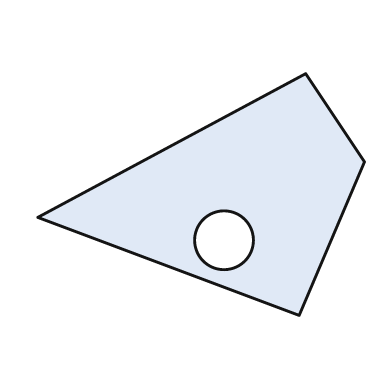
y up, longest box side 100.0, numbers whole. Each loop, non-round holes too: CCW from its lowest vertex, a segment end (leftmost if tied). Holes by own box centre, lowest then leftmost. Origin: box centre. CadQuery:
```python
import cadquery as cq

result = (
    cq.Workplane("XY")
    .moveTo(30.0, -37.0)
    .lineTo(50.0, 10.0)
    .lineTo(32.0, 37.0)
    .lineTo(-50.0, -7.0)
    .close()
    .moveTo(7.0, -14.0)
    .circle(9.0)
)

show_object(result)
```